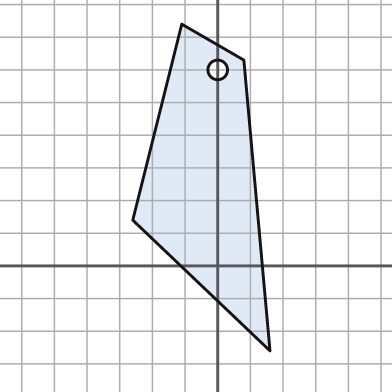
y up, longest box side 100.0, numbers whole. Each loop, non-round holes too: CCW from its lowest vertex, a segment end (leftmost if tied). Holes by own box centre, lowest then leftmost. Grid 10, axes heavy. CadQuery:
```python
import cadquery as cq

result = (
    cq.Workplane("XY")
    .moveTo(16.0, -26.0)
    .lineTo(8.0, 63.0)
    .lineTo(-11.0, 74.0)
    .lineTo(-26.0, 14.0)
    .close()
    .moveTo(0.0, 60.0)
    .circle(3.0)
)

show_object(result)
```